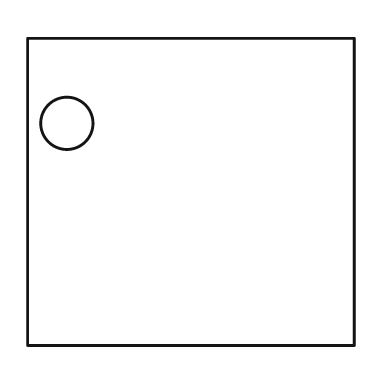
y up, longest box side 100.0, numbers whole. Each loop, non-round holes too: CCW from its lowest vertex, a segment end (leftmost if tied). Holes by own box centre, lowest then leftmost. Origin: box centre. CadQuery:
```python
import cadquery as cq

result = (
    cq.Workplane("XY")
    .moveTo(-50.0, -47.0)
    .lineTo(50.0, -47.0)
    .lineTo(50.0, 47.0)
    .lineTo(-50.0, 47.0)
    .close()
    .moveTo(-38.0, 21.0)
    .circle(8.0)
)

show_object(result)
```